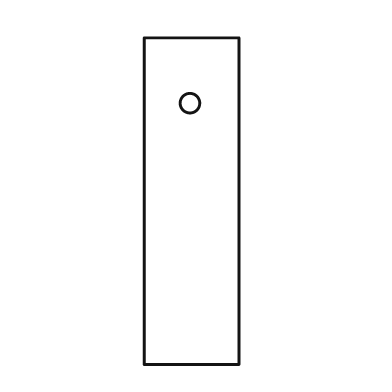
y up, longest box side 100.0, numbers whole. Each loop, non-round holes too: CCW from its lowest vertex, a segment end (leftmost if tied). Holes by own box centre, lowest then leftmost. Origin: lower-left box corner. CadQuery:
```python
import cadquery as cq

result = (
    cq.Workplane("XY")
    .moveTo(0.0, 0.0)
    .lineTo(29.0, 0.0)
    .lineTo(29.0, 100.0)
    .lineTo(0.0, 100.0)
    .close()
    .moveTo(14.0, 80.0)
    .circle(3.0)
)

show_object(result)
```